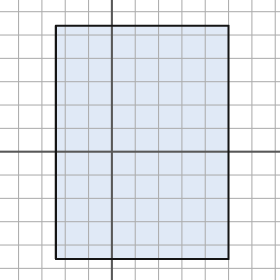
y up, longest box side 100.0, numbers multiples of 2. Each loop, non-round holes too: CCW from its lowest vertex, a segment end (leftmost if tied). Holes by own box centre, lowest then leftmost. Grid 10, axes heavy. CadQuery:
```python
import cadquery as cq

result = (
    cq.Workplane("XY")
    .moveTo(-24.0, -46.0)
    .lineTo(50.0, -46.0)
    .lineTo(50.0, 54.0)
    .lineTo(-24.0, 54.0)
    .close()
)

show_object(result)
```